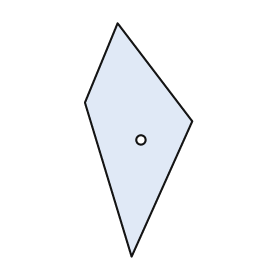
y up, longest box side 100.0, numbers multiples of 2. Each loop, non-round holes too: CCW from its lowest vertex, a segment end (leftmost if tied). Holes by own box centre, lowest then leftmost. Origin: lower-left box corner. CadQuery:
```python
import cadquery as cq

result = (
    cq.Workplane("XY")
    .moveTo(20.0, 0.0)
    .lineTo(46.0, 58.0)
    .lineTo(14.0, 100.0)
    .lineTo(0.0, 66.0)
    .close()
    .moveTo(24.0, 50.0)
    .circle(2.0)
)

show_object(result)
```